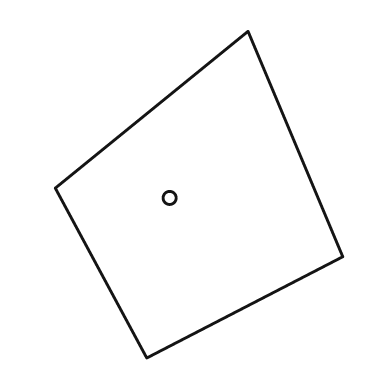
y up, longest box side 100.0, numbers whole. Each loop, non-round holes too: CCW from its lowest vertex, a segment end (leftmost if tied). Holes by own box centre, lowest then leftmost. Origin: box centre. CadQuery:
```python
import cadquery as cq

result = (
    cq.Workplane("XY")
    .moveTo(-16.0, -50.0)
    .lineTo(44.0, -19.0)
    .lineTo(15.0, 50.0)
    .lineTo(-44.0, 2.0)
    .close()
    .moveTo(-9.0, -1.0)
    .circle(2.0)
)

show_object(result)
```